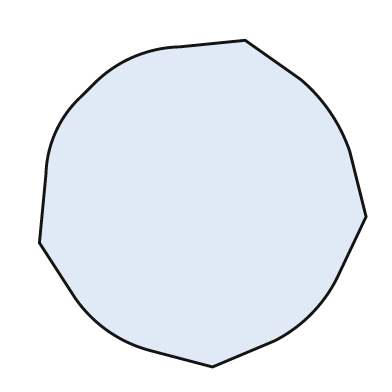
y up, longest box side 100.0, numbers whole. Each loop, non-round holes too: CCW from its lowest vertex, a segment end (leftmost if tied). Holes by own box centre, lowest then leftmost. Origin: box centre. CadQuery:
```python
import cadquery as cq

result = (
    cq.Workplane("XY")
    .moveTo(3.0, -50.0)
    .lineTo(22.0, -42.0)
    .threePointArc((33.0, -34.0), (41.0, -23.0))
    .lineTo(50.0, -4.0)
    .lineTo(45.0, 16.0)
    .threePointArc((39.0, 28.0), (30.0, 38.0))
    .lineTo(13.0, 50.0)
    .lineTo(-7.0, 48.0)
    .threePointArc((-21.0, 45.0), (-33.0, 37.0))
    .lineTo(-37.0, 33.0)
    .threePointArc((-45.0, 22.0), (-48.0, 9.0))
    .lineTo(-50.0, -12.0)
    .lineTo(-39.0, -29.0)
    .threePointArc((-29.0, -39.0), (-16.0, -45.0))
    .close()
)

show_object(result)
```